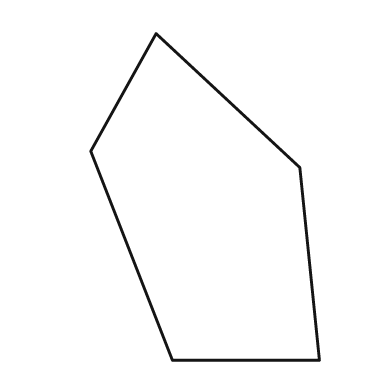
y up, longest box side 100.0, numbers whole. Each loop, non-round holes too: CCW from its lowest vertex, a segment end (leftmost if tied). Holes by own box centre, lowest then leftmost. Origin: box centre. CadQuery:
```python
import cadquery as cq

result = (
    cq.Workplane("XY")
    .moveTo(-10.0, -50.0)
    .lineTo(35.0, -50.0)
    .lineTo(29.0, 9.0)
    .lineTo(-15.0, 50.0)
    .lineTo(-35.0, 14.0)
    .close()
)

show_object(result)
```